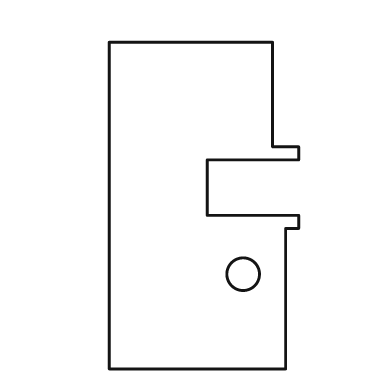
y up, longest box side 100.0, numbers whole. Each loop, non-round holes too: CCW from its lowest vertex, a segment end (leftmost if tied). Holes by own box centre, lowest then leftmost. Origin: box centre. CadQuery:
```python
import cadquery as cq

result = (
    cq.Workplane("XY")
    .moveTo(-29.0, -50.0)
    .lineTo(25.0, -50.0)
    .lineTo(25.0, -7.0)
    .lineTo(29.0, -7.0)
    .lineTo(29.0, -3.0)
    .lineTo(1.0, -3.0)
    .lineTo(1.0, 14.0)
    .lineTo(29.0, 14.0)
    .lineTo(29.0, 18.0)
    .lineTo(21.0, 18.0)
    .lineTo(21.0, 50.0)
    .lineTo(-29.0, 50.0)
    .close()
    .moveTo(12.0, -21.0)
    .circle(5.0)
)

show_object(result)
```